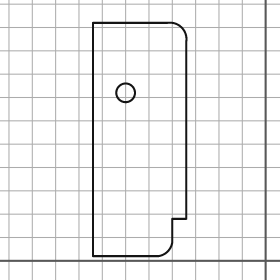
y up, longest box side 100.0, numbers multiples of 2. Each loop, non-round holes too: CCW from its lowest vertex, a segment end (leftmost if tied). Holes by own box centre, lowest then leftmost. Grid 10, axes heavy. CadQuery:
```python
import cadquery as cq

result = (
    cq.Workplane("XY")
    .moveTo(-74.0, 2.0)
    .lineTo(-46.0, 2.0)
    .threePointArc((-42.0, 4.0), (-40.0, 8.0))
    .lineTo(-40.0, 18.0)
    .lineTo(-34.0, 18.0)
    .lineTo(-34.0, 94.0)
    .threePointArc((-36.0, 100.0), (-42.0, 102.0))
    .lineTo(-74.0, 102.0)
    .close()
    .moveTo(-60.0, 72.0)
    .circle(4.0)
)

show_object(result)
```